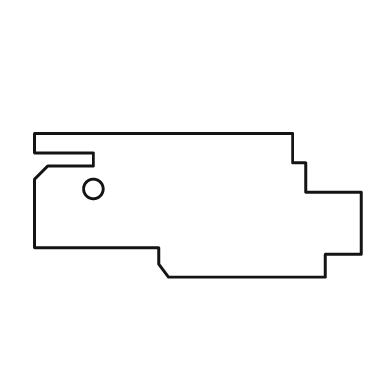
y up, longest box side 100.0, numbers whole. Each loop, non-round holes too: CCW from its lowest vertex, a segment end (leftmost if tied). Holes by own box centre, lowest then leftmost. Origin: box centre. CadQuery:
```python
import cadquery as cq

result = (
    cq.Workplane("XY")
    .moveTo(-9.0, -22.0)
    .lineTo(39.0, -22.0)
    .lineTo(39.0, -15.0)
    .lineTo(50.0, -15.0)
    .lineTo(50.0, 4.0)
    .lineTo(33.0, 4.0)
    .lineTo(33.0, 13.0)
    .lineTo(29.0, 13.0)
    .lineTo(29.0, 22.0)
    .lineTo(-50.0, 22.0)
    .lineTo(-50.0, 16.0)
    .lineTo(-32.0, 16.0)
    .lineTo(-32.0, 12.0)
    .lineTo(-46.0, 12.0)
    .lineTo(-50.0, 8.0)
    .lineTo(-50.0, -13.0)
    .lineTo(-12.0, -13.0)
    .lineTo(-12.0, -18.0)
    .close()
    .moveTo(-32.0, 5.0)
    .circle(3.0)
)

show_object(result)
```